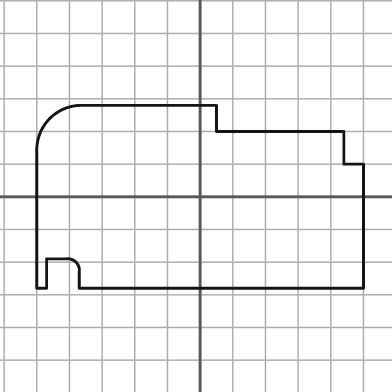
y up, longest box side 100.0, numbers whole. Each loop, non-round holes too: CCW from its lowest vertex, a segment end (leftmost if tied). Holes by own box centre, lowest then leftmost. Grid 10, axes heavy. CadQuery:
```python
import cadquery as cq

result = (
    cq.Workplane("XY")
    .moveTo(-50.0, -28.0)
    .lineTo(-47.0, -28.0)
    .lineTo(-47.0, -19.0)
    .lineTo(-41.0, -19.0)
    .threePointArc((-38.0, -20.0), (-37.0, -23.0))
    .lineTo(-37.0, -28.0)
    .lineTo(50.0, -28.0)
    .lineTo(50.0, 10.0)
    .lineTo(44.0, 10.0)
    .lineTo(44.0, 20.0)
    .lineTo(5.0, 20.0)
    .lineTo(5.0, 28.0)
    .lineTo(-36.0, 28.0)
    .threePointArc((-46.0, 24.0), (-50.0, 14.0))
    .close()
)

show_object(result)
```